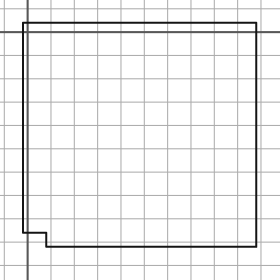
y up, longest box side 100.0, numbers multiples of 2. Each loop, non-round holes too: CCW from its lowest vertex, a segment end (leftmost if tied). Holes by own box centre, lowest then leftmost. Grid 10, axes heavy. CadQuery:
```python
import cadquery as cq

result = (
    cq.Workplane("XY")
    .moveTo(8.0, -92.0)
    .lineTo(98.0, -92.0)
    .lineTo(98.0, 4.0)
    .lineTo(-2.0, 4.0)
    .lineTo(-2.0, -86.0)
    .lineTo(8.0, -86.0)
    .close()
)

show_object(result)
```